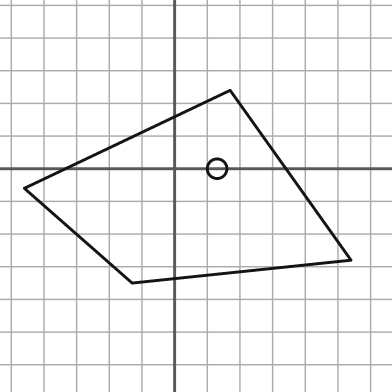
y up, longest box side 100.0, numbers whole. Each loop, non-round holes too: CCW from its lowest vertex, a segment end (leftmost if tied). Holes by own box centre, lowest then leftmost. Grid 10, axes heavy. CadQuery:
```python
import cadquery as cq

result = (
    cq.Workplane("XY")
    .moveTo(-13.0, -35.0)
    .lineTo(54.0, -28.0)
    .lineTo(17.0, 24.0)
    .lineTo(-46.0, -6.0)
    .close()
    .moveTo(13.0, 0.0)
    .circle(3.0)
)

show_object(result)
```